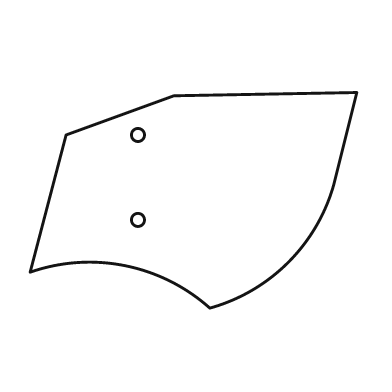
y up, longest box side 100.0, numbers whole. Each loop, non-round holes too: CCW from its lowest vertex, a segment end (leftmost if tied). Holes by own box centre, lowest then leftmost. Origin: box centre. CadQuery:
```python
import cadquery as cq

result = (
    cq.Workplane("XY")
    .moveTo(5.0, -33.0)
    .threePointArc((29.0, -19.0), (43.0, 5.0))
    .lineTo(50.0, 33.0)
    .lineTo(-6.0, 32.0)
    .lineTo(-39.0, 20.0)
    .lineTo(-50.0, -22.0)
    .threePointArc((-21.0, -20.0), (5.0, -33.0))
    .close()
    .moveTo(-17.0, -6.0)
    .circle(2.0)
    .moveTo(-17.0, 20.0)
    .circle(2.0)
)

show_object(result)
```